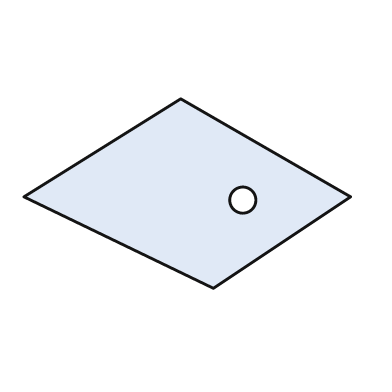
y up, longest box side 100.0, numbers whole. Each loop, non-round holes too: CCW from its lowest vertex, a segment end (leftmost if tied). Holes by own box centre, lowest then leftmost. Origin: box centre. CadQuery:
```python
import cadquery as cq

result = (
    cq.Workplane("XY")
    .moveTo(8.0, -29.0)
    .lineTo(50.0, -1.0)
    .lineTo(-2.0, 29.0)
    .lineTo(-50.0, -1.0)
    .close()
    .moveTo(17.0, -2.0)
    .circle(4.0)
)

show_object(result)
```